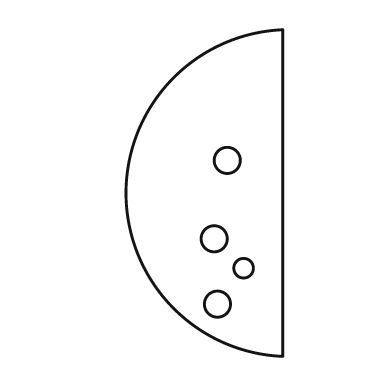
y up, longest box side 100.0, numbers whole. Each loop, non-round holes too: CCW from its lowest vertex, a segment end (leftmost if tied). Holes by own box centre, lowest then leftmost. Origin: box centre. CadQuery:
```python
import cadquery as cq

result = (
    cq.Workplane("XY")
    .moveTo(24.0, -50.0)
    .lineTo(24.0, 50.0)
    .threePointArc((-24.0, 0.0), (24.0, -50.0))
    .close()
    .moveTo(4.0, -34.0)
    .circle(4.0)
    .moveTo(12.0, -23.0)
    .circle(3.0)
    .moveTo(3.0, -14.0)
    .circle(4.0)
    .moveTo(7.0, 10.0)
    .circle(4.0)
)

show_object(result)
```